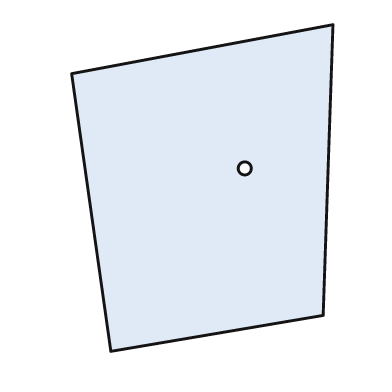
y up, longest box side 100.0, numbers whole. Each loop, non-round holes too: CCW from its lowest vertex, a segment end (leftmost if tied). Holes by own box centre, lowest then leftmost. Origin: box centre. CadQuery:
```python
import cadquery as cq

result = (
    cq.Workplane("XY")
    .moveTo(-28.0, -50.0)
    .lineTo(37.0, -39.0)
    .lineTo(40.0, 50.0)
    .lineTo(-40.0, 35.0)
    .close()
    .moveTo(13.0, 6.0)
    .circle(2.0)
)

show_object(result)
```